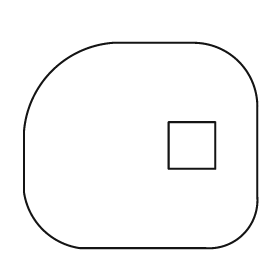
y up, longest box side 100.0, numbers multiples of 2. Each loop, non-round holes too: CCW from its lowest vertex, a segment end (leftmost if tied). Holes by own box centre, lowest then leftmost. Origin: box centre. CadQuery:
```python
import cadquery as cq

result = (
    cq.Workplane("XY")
    .moveTo(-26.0, -44.0)
    .lineTo(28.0, -44.0)
    .threePointArc((44.0, -38.0), (50.0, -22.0))
    .lineTo(50.0, 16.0)
    .threePointArc((42.0, 36.0), (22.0, 44.0))
    .lineTo(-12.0, 44.0)
    .threePointArc((-38.0, 32.0), (-50.0, 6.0))
    .lineTo(-50.0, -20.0)
    .threePointArc((-42.0, -36.0), (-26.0, -44.0))
    .close()
    .moveTo(12.0, -10.0)
    .lineTo(32.0, -10.0)
    .lineTo(32.0, 10.0)
    .lineTo(12.0, 10.0)
    .close()
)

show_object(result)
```